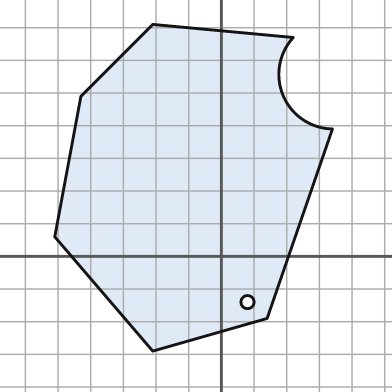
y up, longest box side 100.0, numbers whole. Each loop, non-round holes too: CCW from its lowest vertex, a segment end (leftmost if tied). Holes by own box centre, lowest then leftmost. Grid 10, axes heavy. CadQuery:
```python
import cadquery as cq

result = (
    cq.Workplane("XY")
    .moveTo(-21.0, -29.0)
    .lineTo(14.0, -19.0)
    .lineTo(34.0, 39.0)
    .threePointArc((19.0, 49.0), (22.0, 67.0))
    .lineTo(-21.0, 71.0)
    .lineTo(-43.0, 49.0)
    .lineTo(-51.0, 6.0)
    .close()
    .moveTo(8.0, -14.0)
    .circle(2.0)
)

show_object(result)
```